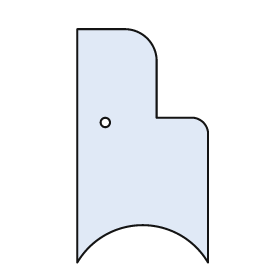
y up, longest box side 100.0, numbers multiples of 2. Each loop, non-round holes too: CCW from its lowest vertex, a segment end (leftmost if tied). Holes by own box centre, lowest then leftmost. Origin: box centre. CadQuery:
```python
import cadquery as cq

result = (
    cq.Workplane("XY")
    .moveTo(-28.0, -50.0)
    .threePointArc((0.0, -34.0), (28.0, -50.0))
    .lineTo(28.0, 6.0)
    .threePointArc((26.0, 10.0), (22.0, 12.0))
    .lineTo(6.0, 12.0)
    .lineTo(6.0, 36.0)
    .threePointArc((2.0, 46.0), (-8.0, 50.0))
    .lineTo(-28.0, 50.0)
    .close()
    .moveTo(-16.0, 10.0)
    .circle(2.0)
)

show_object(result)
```